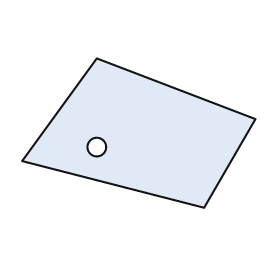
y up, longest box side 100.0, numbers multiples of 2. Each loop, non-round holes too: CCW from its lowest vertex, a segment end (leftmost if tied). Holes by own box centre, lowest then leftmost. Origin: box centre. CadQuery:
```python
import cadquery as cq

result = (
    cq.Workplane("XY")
    .moveTo(28.0, -32.0)
    .lineTo(50.0, 6.0)
    .lineTo(-18.0, 32.0)
    .lineTo(-50.0, -12.0)
    .close()
    .moveTo(-18.0, -6.0)
    .circle(4.0)
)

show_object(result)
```